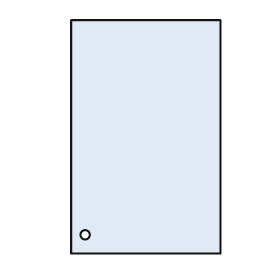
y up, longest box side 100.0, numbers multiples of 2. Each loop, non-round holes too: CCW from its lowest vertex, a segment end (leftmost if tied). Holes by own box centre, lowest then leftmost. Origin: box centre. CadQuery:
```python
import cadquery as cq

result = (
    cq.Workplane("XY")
    .moveTo(-32.0, -50.0)
    .lineTo(32.0, -50.0)
    .lineTo(32.0, 50.0)
    .lineTo(-32.0, 50.0)
    .close()
    .moveTo(-26.0, -42.0)
    .circle(2.0)
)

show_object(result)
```